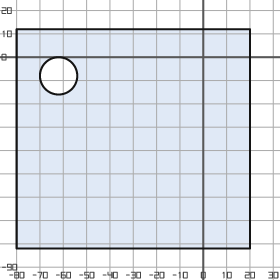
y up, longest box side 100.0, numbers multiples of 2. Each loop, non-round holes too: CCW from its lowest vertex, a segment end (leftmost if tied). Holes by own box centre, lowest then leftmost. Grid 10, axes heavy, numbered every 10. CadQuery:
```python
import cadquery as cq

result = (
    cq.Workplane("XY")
    .moveTo(-80.0, -82.0)
    .lineTo(20.0, -82.0)
    .lineTo(20.0, 12.0)
    .lineTo(-80.0, 12.0)
    .close()
    .moveTo(-62.0, -8.0)
    .circle(8.0)
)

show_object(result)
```